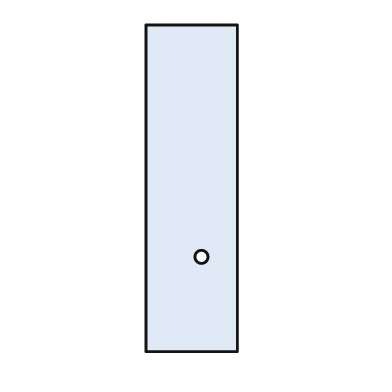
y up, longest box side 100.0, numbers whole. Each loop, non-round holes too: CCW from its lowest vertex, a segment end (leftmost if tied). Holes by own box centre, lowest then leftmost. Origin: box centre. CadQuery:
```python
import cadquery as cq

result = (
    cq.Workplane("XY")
    .moveTo(-14.0, -50.0)
    .lineTo(14.0, -50.0)
    .lineTo(14.0, 50.0)
    .lineTo(-14.0, 50.0)
    .close()
    .moveTo(3.0, -21.0)
    .circle(2.0)
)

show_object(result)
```